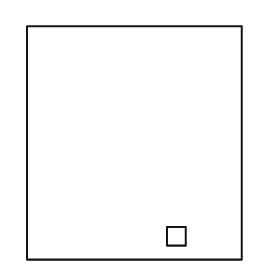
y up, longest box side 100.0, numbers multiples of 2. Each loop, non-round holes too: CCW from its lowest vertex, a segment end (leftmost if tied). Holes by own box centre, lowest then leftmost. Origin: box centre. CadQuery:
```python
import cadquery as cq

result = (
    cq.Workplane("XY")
    .moveTo(-46.0, -50.0)
    .lineTo(46.0, -50.0)
    .lineTo(46.0, 50.0)
    .lineTo(-46.0, 50.0)
    .close()
    .moveTo(14.0, -44.0)
    .lineTo(22.0, -44.0)
    .lineTo(22.0, -36.0)
    .lineTo(14.0, -36.0)
    .close()
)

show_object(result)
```